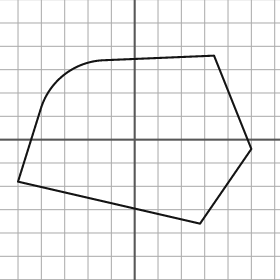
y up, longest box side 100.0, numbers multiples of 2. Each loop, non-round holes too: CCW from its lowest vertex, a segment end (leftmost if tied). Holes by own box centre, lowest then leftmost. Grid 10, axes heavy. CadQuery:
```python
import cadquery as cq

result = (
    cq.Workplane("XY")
    .moveTo(28.0, -36.0)
    .lineTo(50.0, -4.0)
    .lineTo(34.0, 36.0)
    .lineTo(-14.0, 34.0)
    .threePointArc((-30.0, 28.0), (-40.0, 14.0))
    .lineTo(-50.0, -18.0)
    .close()
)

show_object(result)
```